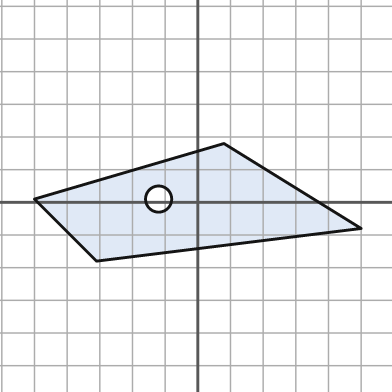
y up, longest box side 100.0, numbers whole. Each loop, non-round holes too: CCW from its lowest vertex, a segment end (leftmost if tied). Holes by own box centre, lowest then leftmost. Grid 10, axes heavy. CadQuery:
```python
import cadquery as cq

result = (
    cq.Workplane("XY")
    .moveTo(-31.0, -18.0)
    .lineTo(50.0, -8.0)
    .lineTo(8.0, 18.0)
    .lineTo(-50.0, 1.0)
    .close()
    .moveTo(-12.0, 1.0)
    .circle(4.0)
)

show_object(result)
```